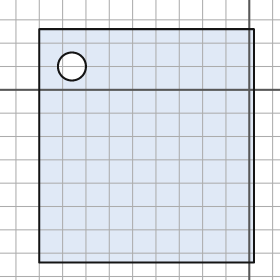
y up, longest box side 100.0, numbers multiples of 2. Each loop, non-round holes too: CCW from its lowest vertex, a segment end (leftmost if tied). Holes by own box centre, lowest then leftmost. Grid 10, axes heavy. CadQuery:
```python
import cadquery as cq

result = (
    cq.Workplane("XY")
    .moveTo(-90.0, -74.0)
    .lineTo(2.0, -74.0)
    .lineTo(2.0, 26.0)
    .lineTo(-90.0, 26.0)
    .close()
    .moveTo(-76.0, 10.0)
    .circle(6.0)
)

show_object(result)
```